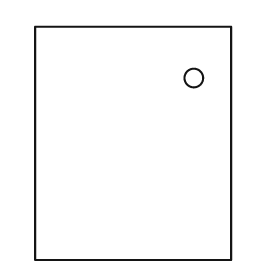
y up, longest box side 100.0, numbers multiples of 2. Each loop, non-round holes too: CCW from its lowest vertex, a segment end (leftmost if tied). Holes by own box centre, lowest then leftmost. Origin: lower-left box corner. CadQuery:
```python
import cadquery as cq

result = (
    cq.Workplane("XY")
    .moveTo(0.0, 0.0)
    .lineTo(84.0, 0.0)
    .lineTo(84.0, 100.0)
    .lineTo(0.0, 100.0)
    .close()
    .moveTo(68.0, 78.0)
    .circle(4.0)
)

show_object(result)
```